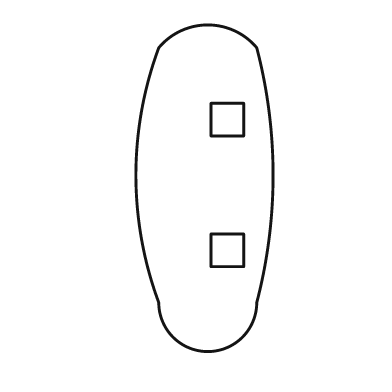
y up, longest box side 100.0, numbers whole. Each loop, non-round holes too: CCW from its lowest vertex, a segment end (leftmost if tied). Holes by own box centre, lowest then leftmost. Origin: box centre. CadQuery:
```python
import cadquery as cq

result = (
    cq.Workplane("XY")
    .moveTo(-14.0, -35.0)
    .threePointArc((1.0, -50.0), (16.0, -35.0))
    .threePointArc((21.0, 4.0), (16.0, 43.0))
    .threePointArc((1.0, 50.0), (-14.0, 43.0))
    .threePointArc((-21.0, 4.0), (-14.0, -35.0))
    .close()
    .moveTo(2.0, -24.0)
    .lineTo(12.0, -24.0)
    .lineTo(12.0, -14.0)
    .lineTo(2.0, -14.0)
    .close()
    .moveTo(2.0, 16.0)
    .lineTo(12.0, 16.0)
    .lineTo(12.0, 26.0)
    .lineTo(2.0, 26.0)
    .close()
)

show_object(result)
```